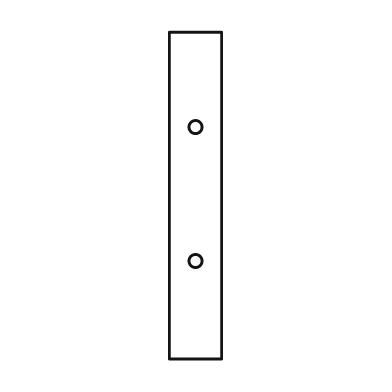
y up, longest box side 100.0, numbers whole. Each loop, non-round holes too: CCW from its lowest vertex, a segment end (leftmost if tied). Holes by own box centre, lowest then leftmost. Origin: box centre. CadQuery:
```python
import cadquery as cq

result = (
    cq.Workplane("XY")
    .moveTo(-8.0, -50.0)
    .lineTo(8.0, -50.0)
    .lineTo(8.0, 50.0)
    .lineTo(-8.0, 50.0)
    .close()
    .moveTo(0.0, -20.0)
    .circle(2.0)
    .moveTo(0.0, 21.0)
    .circle(2.0)
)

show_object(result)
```